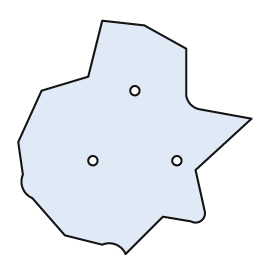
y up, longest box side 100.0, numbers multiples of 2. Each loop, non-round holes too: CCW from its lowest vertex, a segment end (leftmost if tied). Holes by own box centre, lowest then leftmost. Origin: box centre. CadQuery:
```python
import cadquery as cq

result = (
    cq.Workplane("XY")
    .moveTo(-4.0, -50.0)
    .lineTo(12.0, -34.0)
    .lineTo(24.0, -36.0)
    .threePointArc((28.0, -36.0), (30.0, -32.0))
    .lineTo(26.0, -14.0)
    .lineTo(50.0, 8.0)
    .lineTo(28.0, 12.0)
    .threePointArc((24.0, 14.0), (22.0, 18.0))
    .lineTo(22.0, 38.0)
    .lineTo(4.0, 48.0)
    .lineTo(-14.0, 50.0)
    .lineTo(-20.0, 26.0)
    .lineTo(-40.0, 20.0)
    .lineTo(-50.0, -2.0)
    .lineTo(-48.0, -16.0)
    .threePointArc((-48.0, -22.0), (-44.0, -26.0))
    .lineTo(-30.0, -42.0)
    .lineTo(-14.0, -46.0)
    .threePointArc((-8.0, -46.0), (-4.0, -50.0))
    .close()
    .moveTo(-18.0, -10.0)
    .circle(2.0)
    .moveTo(18.0, -10.0)
    .circle(2.0)
    .moveTo(0.0, 20.0)
    .circle(2.0)
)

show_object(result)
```